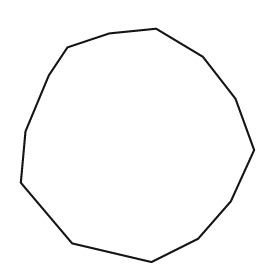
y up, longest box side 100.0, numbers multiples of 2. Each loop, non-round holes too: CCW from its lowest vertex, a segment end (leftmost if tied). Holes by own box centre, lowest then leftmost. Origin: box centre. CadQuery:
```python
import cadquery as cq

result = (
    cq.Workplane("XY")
    .moveTo(6.0, -50.0)
    .lineTo(26.0, -40.0)
    .lineTo(40.0, -24.0)
    .lineTo(50.0, -2.0)
    .lineTo(42.0, 20.0)
    .lineTo(28.0, 38.0)
    .lineTo(8.0, 50.0)
    .lineTo(-12.0, 48.0)
    .lineTo(-30.0, 42.0)
    .lineTo(-38.0, 30.0)
    .lineTo(-48.0, 6.0)
    .lineTo(-50.0, -16.0)
    .lineTo(-28.0, -42.0)
    .close()
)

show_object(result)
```